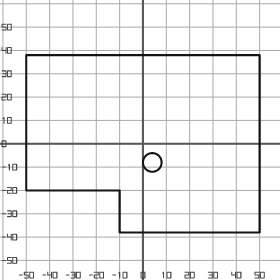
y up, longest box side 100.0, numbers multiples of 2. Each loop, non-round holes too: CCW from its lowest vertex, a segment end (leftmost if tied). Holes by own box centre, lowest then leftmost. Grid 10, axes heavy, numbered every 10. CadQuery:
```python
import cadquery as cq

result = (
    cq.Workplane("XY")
    .moveTo(-10.0, -38.0)
    .lineTo(50.0, -38.0)
    .lineTo(50.0, 38.0)
    .lineTo(-50.0, 38.0)
    .lineTo(-50.0, -20.0)
    .lineTo(-10.0, -20.0)
    .close()
    .moveTo(4.0, -8.0)
    .circle(4.0)
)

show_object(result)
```